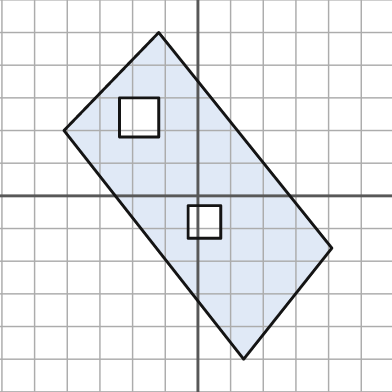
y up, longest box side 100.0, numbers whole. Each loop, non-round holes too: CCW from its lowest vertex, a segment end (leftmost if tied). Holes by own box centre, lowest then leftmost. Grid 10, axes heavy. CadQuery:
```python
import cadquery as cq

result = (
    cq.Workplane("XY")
    .moveTo(14.0, -50.0)
    .lineTo(41.0, -16.0)
    .lineTo(-12.0, 50.0)
    .lineTo(-41.0, 20.0)
    .close()
    .moveTo(-3.0, -13.0)
    .lineTo(7.0, -13.0)
    .lineTo(7.0, -3.0)
    .lineTo(-3.0, -3.0)
    .close()
    .moveTo(-24.0, 18.0)
    .lineTo(-12.0, 18.0)
    .lineTo(-12.0, 30.0)
    .lineTo(-24.0, 30.0)
    .close()
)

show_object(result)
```